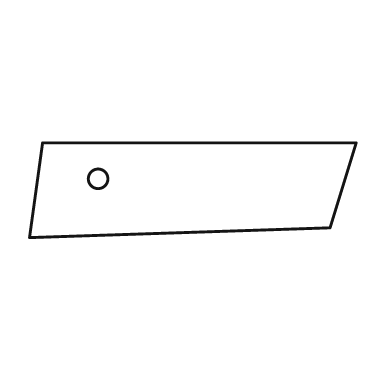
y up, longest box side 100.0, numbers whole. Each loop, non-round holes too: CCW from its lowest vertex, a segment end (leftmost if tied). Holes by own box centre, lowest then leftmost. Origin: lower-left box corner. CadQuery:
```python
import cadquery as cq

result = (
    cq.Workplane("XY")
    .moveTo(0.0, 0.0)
    .lineTo(92.0, 3.0)
    .lineTo(100.0, 29.0)
    .lineTo(4.0, 29.0)
    .close()
    .moveTo(21.0, 18.0)
    .circle(3.0)
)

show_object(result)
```